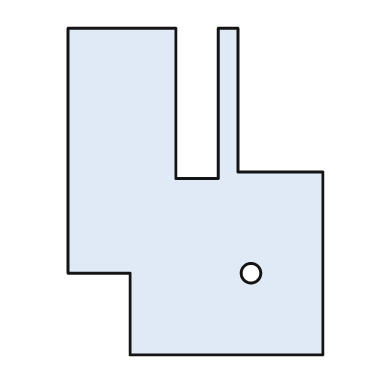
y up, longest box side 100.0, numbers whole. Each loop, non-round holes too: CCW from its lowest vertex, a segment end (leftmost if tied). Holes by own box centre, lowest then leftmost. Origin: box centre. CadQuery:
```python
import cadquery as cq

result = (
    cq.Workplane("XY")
    .moveTo(-20.0, -50.0)
    .lineTo(39.0, -50.0)
    .lineTo(39.0, 6.0)
    .lineTo(13.0, 6.0)
    .lineTo(13.0, 50.0)
    .lineTo(7.0, 50.0)
    .lineTo(7.0, 4.0)
    .lineTo(-6.0, 4.0)
    .lineTo(-6.0, 50.0)
    .lineTo(-39.0, 50.0)
    .lineTo(-39.0, -25.0)
    .lineTo(-20.0, -25.0)
    .close()
    .moveTo(17.0, -25.0)
    .circle(3.0)
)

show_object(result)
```